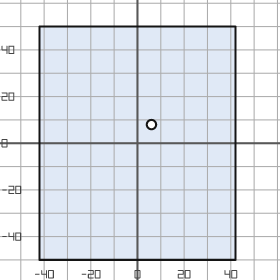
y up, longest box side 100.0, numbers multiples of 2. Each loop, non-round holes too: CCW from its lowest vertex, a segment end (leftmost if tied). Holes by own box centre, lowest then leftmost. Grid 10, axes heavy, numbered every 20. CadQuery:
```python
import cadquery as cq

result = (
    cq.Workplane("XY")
    .moveTo(-42.0, -50.0)
    .lineTo(42.0, -50.0)
    .lineTo(42.0, 50.0)
    .lineTo(-42.0, 50.0)
    .close()
    .moveTo(6.0, 8.0)
    .circle(2.0)
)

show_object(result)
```